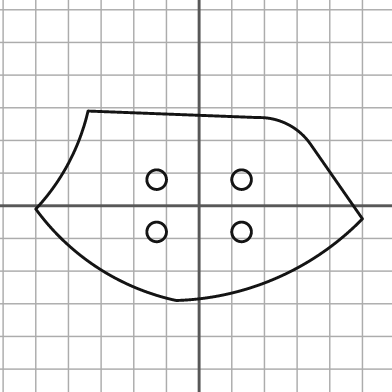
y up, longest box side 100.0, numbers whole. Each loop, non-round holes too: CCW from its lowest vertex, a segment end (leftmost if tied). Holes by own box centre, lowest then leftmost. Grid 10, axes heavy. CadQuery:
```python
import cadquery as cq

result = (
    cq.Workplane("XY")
    .moveTo(-7.0, -29.0)
    .threePointArc((24.0, -22.0), (50.0, -4.0))
    .lineTo(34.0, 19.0)
    .threePointArc((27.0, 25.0), (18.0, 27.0))
    .lineTo(-34.0, 29.0)
    .threePointArc((-40.0, 13.0), (-50.0, -1.0))
    .threePointArc((-31.0, -19.0), (-7.0, -29.0))
    .close()
    .moveTo(-13.0, -8.0)
    .circle(3.0)
    .moveTo(13.0, -8.0)
    .circle(3.0)
    .moveTo(-13.0, 8.0)
    .circle(3.0)
    .moveTo(13.0, 8.0)
    .circle(3.0)
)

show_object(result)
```